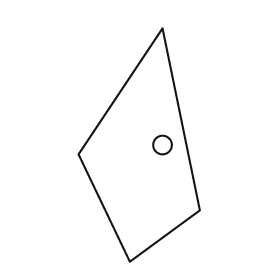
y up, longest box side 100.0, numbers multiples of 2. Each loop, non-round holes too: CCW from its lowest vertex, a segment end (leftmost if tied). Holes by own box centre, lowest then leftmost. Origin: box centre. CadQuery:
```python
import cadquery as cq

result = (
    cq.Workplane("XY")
    .moveTo(-4.0, -50.0)
    .lineTo(26.0, -28.0)
    .lineTo(10.0, 50.0)
    .lineTo(-26.0, -4.0)
    .close()
    .moveTo(10.0, 0.0)
    .circle(4.0)
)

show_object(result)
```